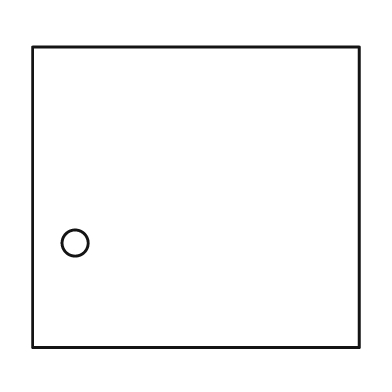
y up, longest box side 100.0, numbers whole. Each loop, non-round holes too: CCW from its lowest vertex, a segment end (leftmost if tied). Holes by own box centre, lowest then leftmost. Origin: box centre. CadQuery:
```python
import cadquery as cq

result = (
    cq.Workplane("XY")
    .moveTo(-50.0, -46.0)
    .lineTo(50.0, -46.0)
    .lineTo(50.0, 46.0)
    .lineTo(-50.0, 46.0)
    .close()
    .moveTo(-37.0, -14.0)
    .circle(4.0)
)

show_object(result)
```